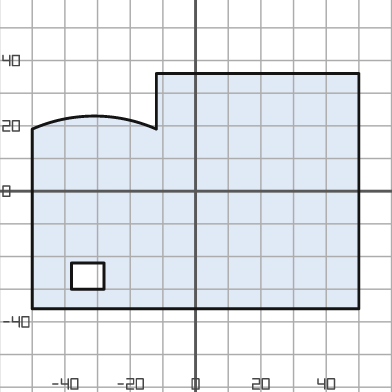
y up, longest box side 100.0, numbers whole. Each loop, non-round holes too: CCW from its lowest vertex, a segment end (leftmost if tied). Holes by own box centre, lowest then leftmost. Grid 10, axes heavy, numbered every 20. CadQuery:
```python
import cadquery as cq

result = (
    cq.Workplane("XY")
    .moveTo(-50.0, -36.0)
    .lineTo(50.0, -36.0)
    .lineTo(50.0, 36.0)
    .lineTo(-12.0, 36.0)
    .lineTo(-12.0, 19.0)
    .threePointArc((-31.0, 23.0), (-50.0, 19.0))
    .close()
    .moveTo(-38.0, -30.0)
    .lineTo(-28.0, -30.0)
    .lineTo(-28.0, -22.0)
    .lineTo(-38.0, -22.0)
    .close()
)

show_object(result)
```